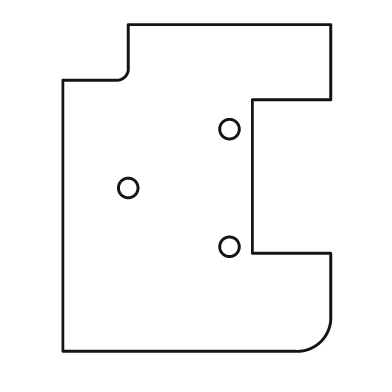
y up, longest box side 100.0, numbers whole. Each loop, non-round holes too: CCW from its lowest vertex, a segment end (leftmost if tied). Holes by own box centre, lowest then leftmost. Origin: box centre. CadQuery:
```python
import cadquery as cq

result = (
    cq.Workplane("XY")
    .moveTo(-41.0, -50.0)
    .lineTo(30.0, -50.0)
    .threePointArc((38.0, -47.0), (41.0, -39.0))
    .lineTo(41.0, -20.0)
    .lineTo(17.0, -20.0)
    .lineTo(17.0, 27.0)
    .lineTo(41.0, 27.0)
    .lineTo(41.0, 50.0)
    .lineTo(-21.0, 50.0)
    .lineTo(-21.0, 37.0)
    .threePointArc((-22.0, 34.0), (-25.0, 33.0))
    .lineTo(-41.0, 33.0)
    .close()
    .moveTo(10.0, -18.0)
    .circle(3.0)
    .moveTo(-21.0, 0.0)
    .circle(3.0)
    .moveTo(10.0, 18.0)
    .circle(3.0)
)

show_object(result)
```